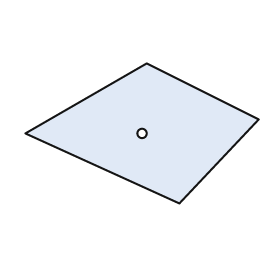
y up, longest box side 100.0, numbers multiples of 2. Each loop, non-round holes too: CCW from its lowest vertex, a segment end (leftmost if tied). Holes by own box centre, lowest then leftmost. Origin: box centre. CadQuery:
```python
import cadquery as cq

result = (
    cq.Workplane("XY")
    .moveTo(16.0, -30.0)
    .lineTo(50.0, 6.0)
    .lineTo(2.0, 30.0)
    .lineTo(-50.0, 0.0)
    .close()
    .moveTo(0.0, 0.0)
    .circle(2.0)
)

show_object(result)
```